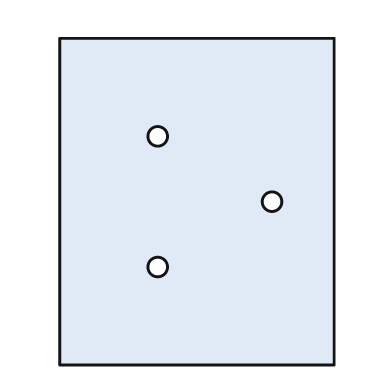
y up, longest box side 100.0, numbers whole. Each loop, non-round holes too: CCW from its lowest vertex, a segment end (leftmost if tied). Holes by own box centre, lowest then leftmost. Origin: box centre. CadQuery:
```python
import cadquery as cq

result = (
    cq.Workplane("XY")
    .moveTo(-42.0, -50.0)
    .lineTo(42.0, -50.0)
    .lineTo(42.0, 50.0)
    .lineTo(-42.0, 50.0)
    .close()
    .moveTo(-12.0, -20.0)
    .circle(3.0)
    .moveTo(23.0, 0.0)
    .circle(3.0)
    .moveTo(-12.0, 20.0)
    .circle(3.0)
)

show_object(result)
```